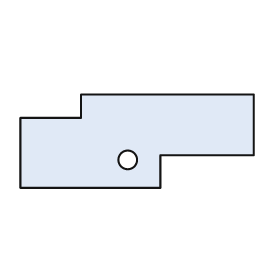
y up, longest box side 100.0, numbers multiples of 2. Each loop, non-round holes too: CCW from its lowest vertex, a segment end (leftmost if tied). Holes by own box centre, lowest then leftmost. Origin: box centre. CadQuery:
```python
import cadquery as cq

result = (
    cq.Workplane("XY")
    .moveTo(-50.0, -20.0)
    .lineTo(10.0, -20.0)
    .lineTo(10.0, -6.0)
    .lineTo(50.0, -6.0)
    .lineTo(50.0, 20.0)
    .lineTo(-24.0, 20.0)
    .lineTo(-24.0, 10.0)
    .lineTo(-50.0, 10.0)
    .close()
    .moveTo(-4.0, -8.0)
    .circle(4.0)
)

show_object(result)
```